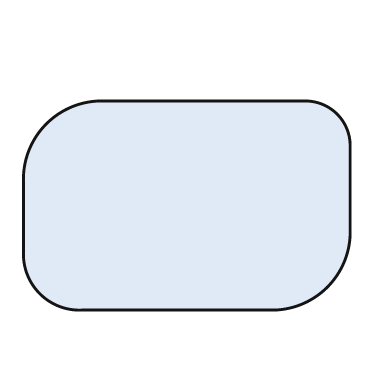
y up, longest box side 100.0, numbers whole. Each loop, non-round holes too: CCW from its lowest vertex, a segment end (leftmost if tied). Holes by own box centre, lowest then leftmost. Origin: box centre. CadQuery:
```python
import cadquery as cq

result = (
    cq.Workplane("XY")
    .moveTo(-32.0, -32.0)
    .lineTo(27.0, -32.0)
    .threePointArc((43.0, -25.0), (50.0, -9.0))
    .lineTo(50.0, 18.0)
    .threePointArc((46.0, 28.0), (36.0, 32.0))
    .lineTo(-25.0, 32.0)
    .threePointArc((-43.0, 25.0), (-50.0, 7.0))
    .lineTo(-50.0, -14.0)
    .threePointArc((-45.0, -27.0), (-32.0, -32.0))
    .close()
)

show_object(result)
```